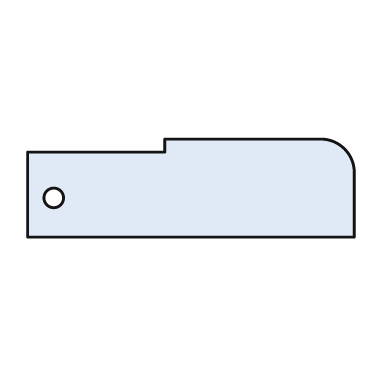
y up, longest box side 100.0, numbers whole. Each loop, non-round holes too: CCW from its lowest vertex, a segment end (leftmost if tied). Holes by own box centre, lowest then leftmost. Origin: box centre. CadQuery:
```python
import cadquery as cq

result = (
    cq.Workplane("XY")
    .moveTo(-50.0, -15.0)
    .lineTo(50.0, -15.0)
    .lineTo(50.0, 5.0)
    .threePointArc((47.0, 12.0), (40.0, 15.0))
    .lineTo(-8.0, 15.0)
    .lineTo(-8.0, 11.0)
    .lineTo(-50.0, 11.0)
    .close()
    .moveTo(-42.0, -3.0)
    .circle(3.0)
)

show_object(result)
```